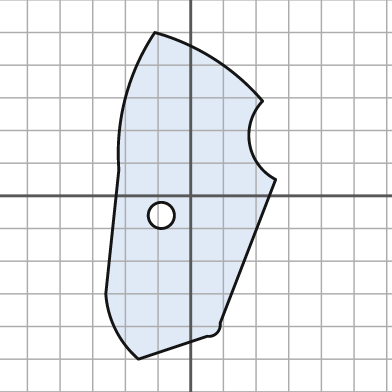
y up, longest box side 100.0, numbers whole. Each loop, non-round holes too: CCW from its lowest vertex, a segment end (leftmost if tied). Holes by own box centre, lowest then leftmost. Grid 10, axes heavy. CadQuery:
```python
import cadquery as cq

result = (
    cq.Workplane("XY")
    .moveTo(-16.0, -50.0)
    .lineTo(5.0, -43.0)
    .threePointArc((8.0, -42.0), (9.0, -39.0))
    .lineTo(26.0, 5.0)
    .threePointArc((18.0, 16.0), (22.0, 29.0))
    .threePointArc((7.0, 42.0), (-11.0, 50.0))
    .threePointArc((-20.0, 30.0), (-22.0, 8.0))
    .lineTo(-26.0, -30.0)
    .threePointArc((-23.0, -41.0), (-16.0, -50.0))
    .close()
    .moveTo(-9.0, -6.0)
    .circle(4.0)
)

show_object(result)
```